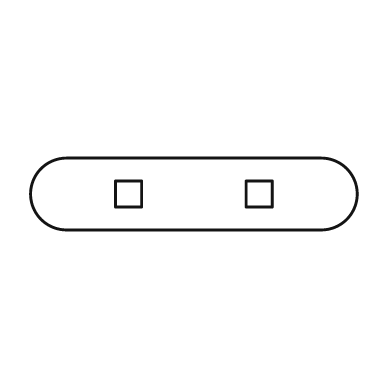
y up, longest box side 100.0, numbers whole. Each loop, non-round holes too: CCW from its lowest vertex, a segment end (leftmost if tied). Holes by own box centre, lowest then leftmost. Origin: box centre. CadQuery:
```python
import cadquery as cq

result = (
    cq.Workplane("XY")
    .moveTo(-39.0, -11.0)
    .lineTo(39.0, -11.0)
    .threePointArc((50.0, 0.0), (39.0, 11.0))
    .lineTo(-39.0, 11.0)
    .threePointArc((-50.0, 0.0), (-39.0, -11.0))
    .close()
    .moveTo(-24.0, -4.0)
    .lineTo(-16.0, -4.0)
    .lineTo(-16.0, 4.0)
    .lineTo(-24.0, 4.0)
    .close()
    .moveTo(16.0, -4.0)
    .lineTo(24.0, -4.0)
    .lineTo(24.0, 4.0)
    .lineTo(16.0, 4.0)
    .close()
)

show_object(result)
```